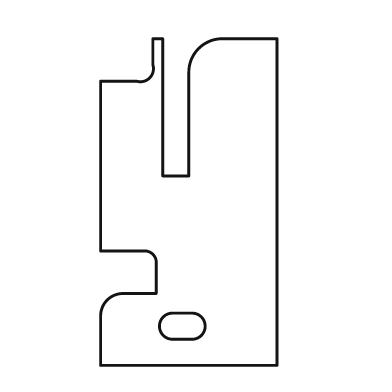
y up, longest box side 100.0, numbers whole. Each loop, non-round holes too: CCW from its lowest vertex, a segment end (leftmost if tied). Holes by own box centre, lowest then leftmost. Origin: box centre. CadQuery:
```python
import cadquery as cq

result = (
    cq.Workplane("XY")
    .moveTo(-27.0, -50.0)
    .lineTo(27.0, -50.0)
    .lineTo(27.0, 50.0)
    .lineTo(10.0, 50.0)
    .threePointArc((3.0, 47.0), (0.0, 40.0))
    .lineTo(0.0, 8.0)
    .lineTo(-8.0, 8.0)
    .lineTo(-8.0, 50.0)
    .lineTo(-11.0, 50.0)
    .lineTo(-11.0, 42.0)
    .threePointArc((-12.0, 38.0), (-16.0, 37.0))
    .lineTo(-27.0, 37.0)
    .lineTo(-27.0, -15.0)
    .lineTo(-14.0, -15.0)
    .threePointArc((-11.0, -16.0), (-10.0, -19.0))
    .lineTo(-10.0, -28.0)
    .lineTo(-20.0, -28.0)
    .threePointArc((-25.0, -30.0), (-27.0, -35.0))
    .close()
    .moveTo(-5.0, -42.0)
    .lineTo(1.0, -42.0)
    .threePointArc((5.0, -38.0), (1.0, -34.0))
    .lineTo(-5.0, -34.0)
    .threePointArc((-9.0, -38.0), (-5.0, -42.0))
    .close()
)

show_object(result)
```